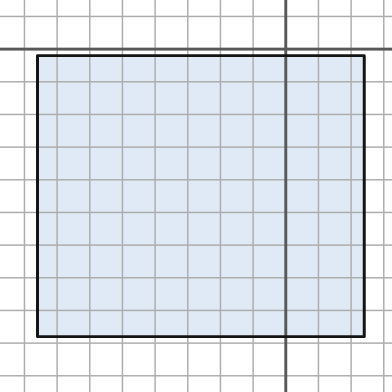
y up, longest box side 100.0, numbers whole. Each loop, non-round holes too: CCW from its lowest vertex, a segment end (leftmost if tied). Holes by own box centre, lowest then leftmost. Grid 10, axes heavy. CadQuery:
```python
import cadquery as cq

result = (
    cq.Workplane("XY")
    .moveTo(-76.0, -88.0)
    .lineTo(24.0, -88.0)
    .lineTo(24.0, -2.0)
    .lineTo(-76.0, -2.0)
    .close()
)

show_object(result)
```